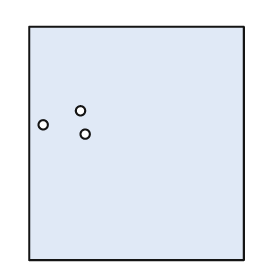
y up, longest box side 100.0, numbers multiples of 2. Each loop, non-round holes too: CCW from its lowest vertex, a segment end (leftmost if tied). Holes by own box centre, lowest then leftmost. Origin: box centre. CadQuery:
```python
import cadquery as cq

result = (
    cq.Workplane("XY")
    .moveTo(-46.0, -50.0)
    .lineTo(46.0, -50.0)
    .lineTo(46.0, 50.0)
    .lineTo(-46.0, 50.0)
    .close()
    .moveTo(-22.0, 4.0)
    .circle(2.0)
    .moveTo(-40.0, 8.0)
    .circle(2.0)
    .moveTo(-24.0, 14.0)
    .circle(2.0)
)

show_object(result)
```